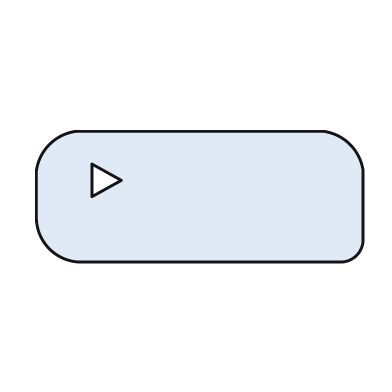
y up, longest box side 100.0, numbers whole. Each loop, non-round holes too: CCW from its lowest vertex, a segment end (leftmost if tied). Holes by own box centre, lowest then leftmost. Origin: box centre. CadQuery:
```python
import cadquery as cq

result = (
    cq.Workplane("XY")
    .moveTo(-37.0, -20.0)
    .lineTo(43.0, -20.0)
    .threePointArc((48.0, -18.0), (50.0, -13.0))
    .lineTo(50.0, 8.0)
    .threePointArc((46.0, 16.0), (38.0, 20.0))
    .lineTo(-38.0, 20.0)
    .threePointArc((-46.0, 16.0), (-50.0, 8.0))
    .lineTo(-50.0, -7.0)
    .threePointArc((-46.0, -16.0), (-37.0, -20.0))
    .close()
    .moveTo(-33.0, 0.0)
    .lineTo(-24.0, 5.0)
    .lineTo(-33.0, 10.0)
    .close()
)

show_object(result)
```